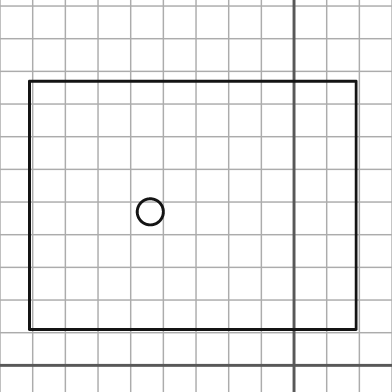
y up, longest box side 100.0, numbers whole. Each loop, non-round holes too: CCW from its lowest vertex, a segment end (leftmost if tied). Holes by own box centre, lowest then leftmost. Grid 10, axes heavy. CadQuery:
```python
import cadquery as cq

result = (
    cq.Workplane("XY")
    .moveTo(-81.0, 11.0)
    .lineTo(19.0, 11.0)
    .lineTo(19.0, 87.0)
    .lineTo(-81.0, 87.0)
    .close()
    .moveTo(-44.0, 47.0)
    .circle(4.0)
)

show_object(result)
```